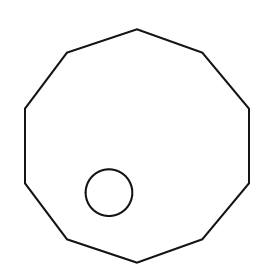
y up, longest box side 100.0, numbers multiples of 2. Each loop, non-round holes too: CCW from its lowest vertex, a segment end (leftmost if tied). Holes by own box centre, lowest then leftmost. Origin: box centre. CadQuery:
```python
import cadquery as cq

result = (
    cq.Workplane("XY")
    .moveTo(0.0, -50.0)
    .lineTo(28.0, -40.0)
    .lineTo(48.0, -16.0)
    .lineTo(48.0, 16.0)
    .lineTo(28.0, 40.0)
    .lineTo(0.0, 50.0)
    .lineTo(-30.0, 40.0)
    .lineTo(-48.0, 16.0)
    .lineTo(-48.0, -16.0)
    .lineTo(-30.0, -40.0)
    .close()
    .moveTo(-12.0, -20.0)
    .circle(10.0)
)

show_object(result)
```